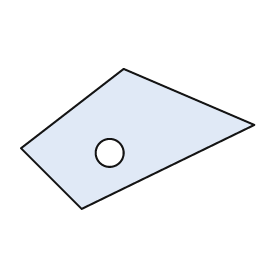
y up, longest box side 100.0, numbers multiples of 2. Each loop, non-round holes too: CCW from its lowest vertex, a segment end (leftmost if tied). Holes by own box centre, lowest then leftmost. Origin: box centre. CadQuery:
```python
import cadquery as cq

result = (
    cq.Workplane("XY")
    .moveTo(-24.0, -30.0)
    .lineTo(50.0, 6.0)
    .lineTo(-6.0, 30.0)
    .lineTo(-50.0, -4.0)
    .close()
    .moveTo(-12.0, -6.0)
    .circle(6.0)
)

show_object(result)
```